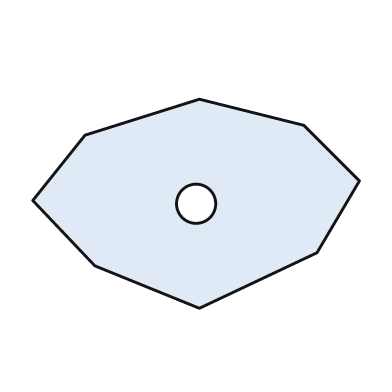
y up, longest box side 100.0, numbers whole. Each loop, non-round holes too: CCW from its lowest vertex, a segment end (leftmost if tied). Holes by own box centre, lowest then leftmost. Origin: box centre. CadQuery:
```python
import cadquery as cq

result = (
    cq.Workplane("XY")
    .moveTo(1.0, -32.0)
    .lineTo(37.0, -15.0)
    .lineTo(50.0, 7.0)
    .lineTo(33.0, 24.0)
    .lineTo(1.0, 32.0)
    .lineTo(-34.0, 21.0)
    .lineTo(-50.0, 1.0)
    .lineTo(-31.0, -19.0)
    .close()
    .moveTo(0.0, 0.0)
    .circle(6.0)
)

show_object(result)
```